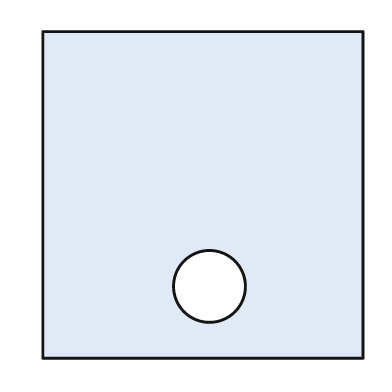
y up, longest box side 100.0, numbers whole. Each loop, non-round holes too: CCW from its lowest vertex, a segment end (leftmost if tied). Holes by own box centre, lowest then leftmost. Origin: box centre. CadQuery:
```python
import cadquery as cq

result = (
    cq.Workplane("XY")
    .moveTo(-49.0, -50.0)
    .lineTo(49.0, -50.0)
    .lineTo(49.0, 50.0)
    .lineTo(-49.0, 50.0)
    .close()
    .moveTo(2.0, -28.0)
    .circle(11.0)
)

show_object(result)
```